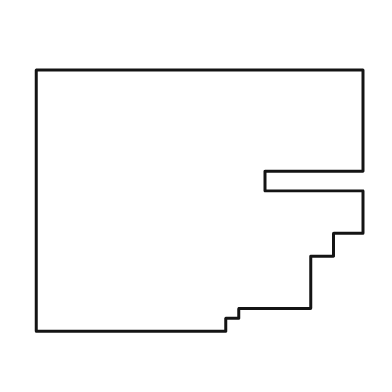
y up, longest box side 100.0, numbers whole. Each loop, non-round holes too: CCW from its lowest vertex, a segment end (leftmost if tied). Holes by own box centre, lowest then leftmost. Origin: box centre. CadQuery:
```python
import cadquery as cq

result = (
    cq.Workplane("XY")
    .moveTo(-50.0, -40.0)
    .lineTo(8.0, -40.0)
    .lineTo(8.0, -36.0)
    .lineTo(12.0, -36.0)
    .lineTo(12.0, -33.0)
    .lineTo(34.0, -33.0)
    .lineTo(34.0, -17.0)
    .lineTo(41.0, -17.0)
    .lineTo(41.0, -10.0)
    .lineTo(50.0, -10.0)
    .lineTo(50.0, 3.0)
    .lineTo(20.0, 3.0)
    .lineTo(20.0, 9.0)
    .lineTo(50.0, 9.0)
    .lineTo(50.0, 40.0)
    .lineTo(-50.0, 40.0)
    .close()
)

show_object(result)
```